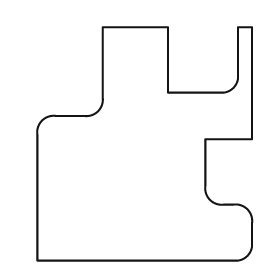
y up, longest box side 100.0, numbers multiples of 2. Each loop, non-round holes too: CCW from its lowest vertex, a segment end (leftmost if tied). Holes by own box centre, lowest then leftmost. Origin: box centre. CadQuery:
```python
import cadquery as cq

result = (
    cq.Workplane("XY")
    .moveTo(-46.0, -50.0)
    .lineTo(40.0, -50.0)
    .threePointArc((44.0, -48.0), (46.0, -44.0))
    .lineTo(46.0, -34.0)
    .threePointArc((44.0, -28.0), (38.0, -26.0))
    .lineTo(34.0, -26.0)
    .threePointArc((28.0, -24.0), (26.0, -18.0))
    .lineTo(26.0, 2.0)
    .lineTo(46.0, 2.0)
    .lineTo(46.0, 50.0)
    .lineTo(40.0, 50.0)
    .lineTo(40.0, 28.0)
    .threePointArc((38.0, 24.0), (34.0, 22.0))
    .lineTo(10.0, 22.0)
    .lineTo(10.0, 50.0)
    .lineTo(-18.0, 50.0)
    .lineTo(-18.0, 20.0)
    .threePointArc((-20.0, 14.0), (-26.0, 12.0))
    .lineTo(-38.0, 12.0)
    .threePointArc((-44.0, 10.0), (-46.0, 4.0))
    .close()
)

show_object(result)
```